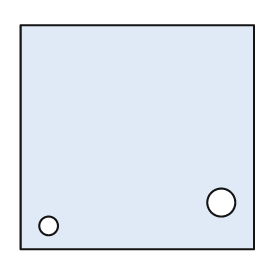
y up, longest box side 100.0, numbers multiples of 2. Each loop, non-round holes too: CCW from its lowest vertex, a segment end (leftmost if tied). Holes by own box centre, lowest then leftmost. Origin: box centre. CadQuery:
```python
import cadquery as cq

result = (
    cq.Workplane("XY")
    .moveTo(-50.0, -48.0)
    .lineTo(50.0, -48.0)
    .lineTo(50.0, 48.0)
    .lineTo(-50.0, 48.0)
    .close()
    .moveTo(-38.0, -38.0)
    .circle(4.0)
    .moveTo(36.0, -28.0)
    .circle(6.0)
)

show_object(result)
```